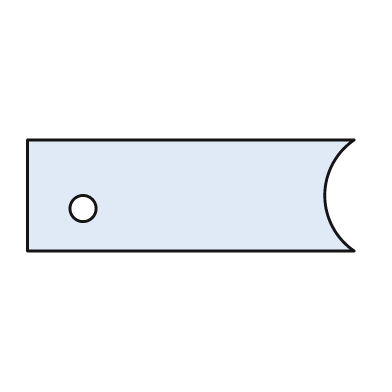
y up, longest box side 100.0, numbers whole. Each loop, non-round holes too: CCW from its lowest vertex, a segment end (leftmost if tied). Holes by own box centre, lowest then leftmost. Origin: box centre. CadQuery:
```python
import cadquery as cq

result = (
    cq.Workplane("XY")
    .moveTo(-50.0, -17.0)
    .lineTo(50.0, -17.0)
    .threePointArc((41.0, 0.0), (50.0, 17.0))
    .lineTo(-50.0, 17.0)
    .close()
    .moveTo(-33.0, -4.0)
    .circle(4.0)
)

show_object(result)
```